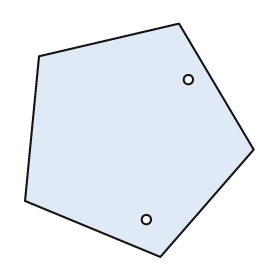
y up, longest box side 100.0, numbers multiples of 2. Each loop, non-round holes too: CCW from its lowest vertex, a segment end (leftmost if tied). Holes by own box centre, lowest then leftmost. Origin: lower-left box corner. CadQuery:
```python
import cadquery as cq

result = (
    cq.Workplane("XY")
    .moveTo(58.0, 0.0)
    .lineTo(98.0, 46.0)
    .lineTo(66.0, 100.0)
    .lineTo(6.0, 86.0)
    .lineTo(0.0, 24.0)
    .close()
    .moveTo(52.0, 16.0)
    .circle(2.0)
    .moveTo(70.0, 76.0)
    .circle(2.0)
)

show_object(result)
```